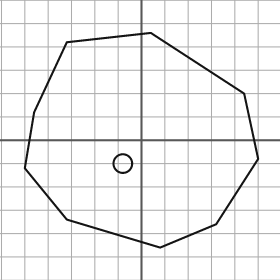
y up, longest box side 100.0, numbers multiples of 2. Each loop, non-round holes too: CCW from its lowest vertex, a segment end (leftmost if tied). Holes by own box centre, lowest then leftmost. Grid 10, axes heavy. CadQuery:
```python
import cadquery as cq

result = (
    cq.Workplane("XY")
    .moveTo(8.0, -46.0)
    .lineTo(32.0, -36.0)
    .lineTo(50.0, -8.0)
    .lineTo(44.0, 20.0)
    .lineTo(4.0, 46.0)
    .lineTo(-32.0, 42.0)
    .lineTo(-46.0, 12.0)
    .lineTo(-50.0, -12.0)
    .lineTo(-32.0, -34.0)
    .close()
    .moveTo(-8.0, -10.0)
    .circle(4.0)
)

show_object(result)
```